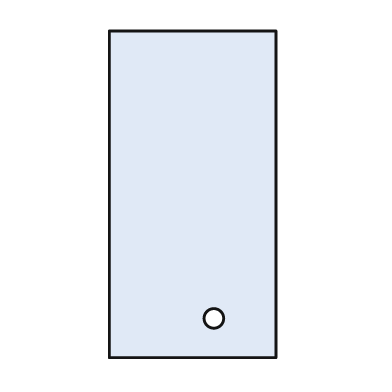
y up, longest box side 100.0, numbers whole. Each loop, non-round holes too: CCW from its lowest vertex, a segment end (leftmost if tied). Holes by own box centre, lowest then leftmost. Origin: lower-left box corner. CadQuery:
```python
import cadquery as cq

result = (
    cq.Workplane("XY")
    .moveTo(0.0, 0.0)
    .lineTo(51.0, 0.0)
    .lineTo(51.0, 100.0)
    .lineTo(0.0, 100.0)
    .close()
    .moveTo(32.0, 12.0)
    .circle(3.0)
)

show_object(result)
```